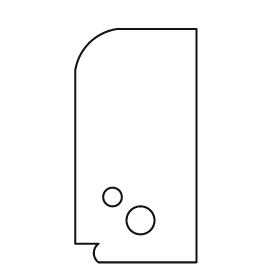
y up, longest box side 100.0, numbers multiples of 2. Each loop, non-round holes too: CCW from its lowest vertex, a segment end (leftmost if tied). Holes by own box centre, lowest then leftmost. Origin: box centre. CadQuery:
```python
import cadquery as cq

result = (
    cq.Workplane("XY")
    .moveTo(-16.0, -50.0)
    .lineTo(26.0, -50.0)
    .lineTo(26.0, 50.0)
    .lineTo(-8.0, 50.0)
    .threePointArc((-20.0, 44.0), (-26.0, 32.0))
    .lineTo(-26.0, -42.0)
    .lineTo(-16.0, -42.0)
    .threePointArc((-18.0, -46.0), (-16.0, -50.0))
    .close()
    .moveTo(2.0, -32.0)
    .circle(6.0)
    .moveTo(-10.0, -22.0)
    .circle(4.0)
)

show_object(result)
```